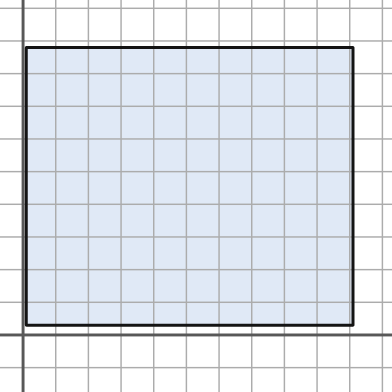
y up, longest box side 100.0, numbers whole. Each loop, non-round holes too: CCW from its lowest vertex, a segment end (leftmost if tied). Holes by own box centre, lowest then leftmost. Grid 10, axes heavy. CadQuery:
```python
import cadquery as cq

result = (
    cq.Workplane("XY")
    .moveTo(1.0, 3.0)
    .lineTo(101.0, 3.0)
    .lineTo(101.0, 88.0)
    .lineTo(1.0, 88.0)
    .close()
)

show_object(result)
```